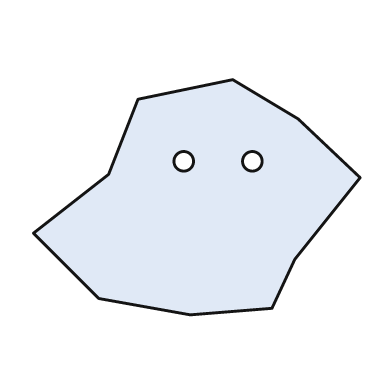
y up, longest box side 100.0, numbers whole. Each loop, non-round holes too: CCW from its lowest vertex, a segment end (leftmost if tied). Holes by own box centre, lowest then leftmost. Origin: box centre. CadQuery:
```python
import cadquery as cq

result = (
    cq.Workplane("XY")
    .moveTo(-2.0, -36.0)
    .lineTo(23.0, -34.0)
    .lineTo(30.0, -19.0)
    .lineTo(50.0, 6.0)
    .lineTo(31.0, 24.0)
    .lineTo(11.0, 36.0)
    .lineTo(-18.0, 30.0)
    .lineTo(-27.0, 7.0)
    .lineTo(-50.0, -11.0)
    .lineTo(-30.0, -31.0)
    .close()
    .moveTo(-4.0, 11.0)
    .circle(3.0)
    .moveTo(17.0, 11.0)
    .circle(3.0)
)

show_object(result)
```